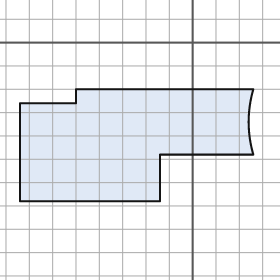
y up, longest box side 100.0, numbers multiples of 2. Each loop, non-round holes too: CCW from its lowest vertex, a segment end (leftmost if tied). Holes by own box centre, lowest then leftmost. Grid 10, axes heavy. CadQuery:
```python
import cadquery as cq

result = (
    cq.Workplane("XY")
    .moveTo(-74.0, -68.0)
    .lineTo(-14.0, -68.0)
    .lineTo(-14.0, -48.0)
    .lineTo(26.0, -48.0)
    .threePointArc((24.0, -34.0), (26.0, -20.0))
    .lineTo(-50.0, -20.0)
    .lineTo(-50.0, -26.0)
    .lineTo(-74.0, -26.0)
    .close()
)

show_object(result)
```